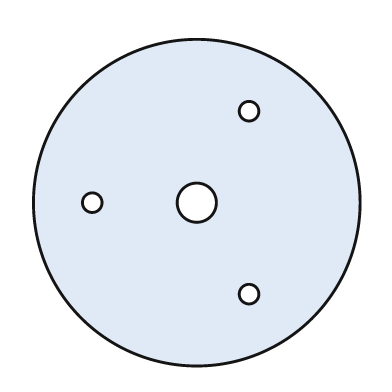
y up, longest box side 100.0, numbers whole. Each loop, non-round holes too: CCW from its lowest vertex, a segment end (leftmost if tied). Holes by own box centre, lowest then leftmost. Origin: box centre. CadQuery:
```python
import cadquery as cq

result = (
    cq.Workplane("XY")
    .moveTo(0.0, 0.0)
    .circle(50.0)
    .moveTo(16.0, -28.0)
    .circle(3.0)
    .moveTo(-32.0, 0.0)
    .circle(3.0)
    .moveTo(0.0, 0.0)
    .circle(6.0)
    .moveTo(16.0, 28.0)
    .circle(3.0)
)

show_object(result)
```